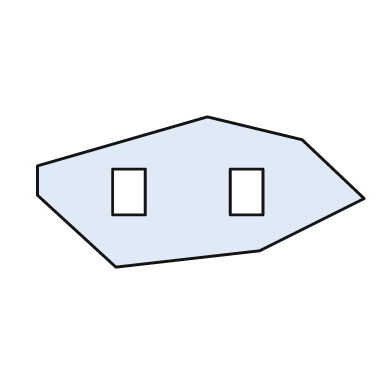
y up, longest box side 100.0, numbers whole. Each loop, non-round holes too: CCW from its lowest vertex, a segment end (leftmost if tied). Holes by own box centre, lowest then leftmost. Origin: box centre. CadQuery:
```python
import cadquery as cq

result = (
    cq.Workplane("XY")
    .moveTo(-26.0, -23.0)
    .lineTo(18.0, -18.0)
    .lineTo(50.0, -2.0)
    .lineTo(31.0, 16.0)
    .lineTo(2.0, 23.0)
    .lineTo(-50.0, 8.0)
    .lineTo(-50.0, -1.0)
    .close()
    .moveTo(-27.0, -7.0)
    .lineTo(-17.0, -7.0)
    .lineTo(-17.0, 7.0)
    .lineTo(-27.0, 7.0)
    .close()
    .moveTo(9.0, -7.0)
    .lineTo(19.0, -7.0)
    .lineTo(19.0, 7.0)
    .lineTo(9.0, 7.0)
    .close()
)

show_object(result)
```